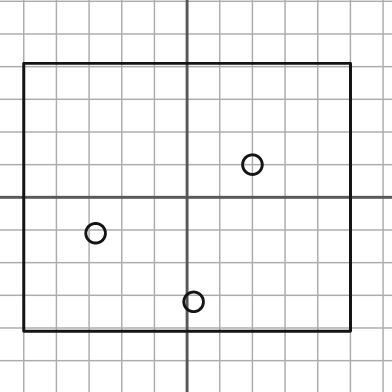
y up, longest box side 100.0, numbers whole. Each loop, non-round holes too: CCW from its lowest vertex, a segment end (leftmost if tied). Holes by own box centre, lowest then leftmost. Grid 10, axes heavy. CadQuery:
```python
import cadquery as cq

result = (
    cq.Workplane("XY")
    .moveTo(-50.0, -41.0)
    .lineTo(50.0, -41.0)
    .lineTo(50.0, 41.0)
    .lineTo(-50.0, 41.0)
    .close()
    .moveTo(2.0, -32.0)
    .circle(3.0)
    .moveTo(-28.0, -11.0)
    .circle(3.0)
    .moveTo(20.0, 10.0)
    .circle(3.0)
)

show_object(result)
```